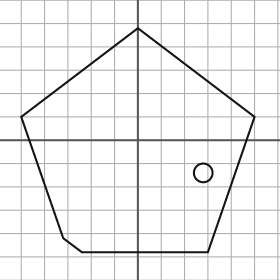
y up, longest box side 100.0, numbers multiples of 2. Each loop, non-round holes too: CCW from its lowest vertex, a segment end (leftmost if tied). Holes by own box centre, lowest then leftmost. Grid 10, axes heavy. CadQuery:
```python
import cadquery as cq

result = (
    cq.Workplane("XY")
    .moveTo(-24.0, -48.0)
    .lineTo(30.0, -48.0)
    .lineTo(50.0, 10.0)
    .lineTo(0.0, 48.0)
    .lineTo(-50.0, 10.0)
    .lineTo(-32.0, -42.0)
    .close()
    .moveTo(28.0, -14.0)
    .circle(4.0)
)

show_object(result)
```